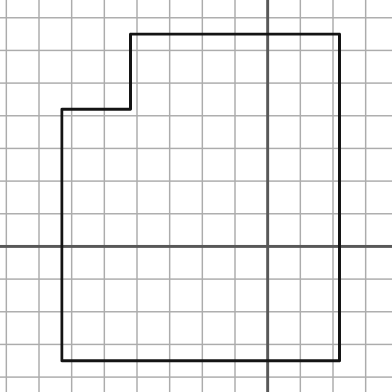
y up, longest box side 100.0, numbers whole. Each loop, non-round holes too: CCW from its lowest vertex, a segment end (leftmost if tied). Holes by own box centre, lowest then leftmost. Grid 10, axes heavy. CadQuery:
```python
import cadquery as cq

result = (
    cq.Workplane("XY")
    .moveTo(-63.0, -35.0)
    .lineTo(22.0, -35.0)
    .lineTo(22.0, 65.0)
    .lineTo(-42.0, 65.0)
    .lineTo(-42.0, 42.0)
    .lineTo(-63.0, 42.0)
    .close()
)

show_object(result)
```